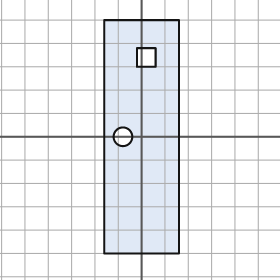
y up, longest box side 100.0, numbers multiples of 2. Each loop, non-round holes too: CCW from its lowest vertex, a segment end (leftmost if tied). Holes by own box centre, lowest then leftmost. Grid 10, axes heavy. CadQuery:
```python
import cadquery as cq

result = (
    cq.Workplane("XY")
    .moveTo(-16.0, -50.0)
    .lineTo(16.0, -50.0)
    .lineTo(16.0, 50.0)
    .lineTo(-16.0, 50.0)
    .close()
    .moveTo(-8.0, 0.0)
    .circle(4.0)
    .moveTo(-2.0, 30.0)
    .lineTo(6.0, 30.0)
    .lineTo(6.0, 38.0)
    .lineTo(-2.0, 38.0)
    .close()
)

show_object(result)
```